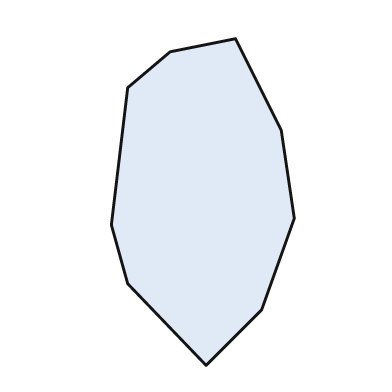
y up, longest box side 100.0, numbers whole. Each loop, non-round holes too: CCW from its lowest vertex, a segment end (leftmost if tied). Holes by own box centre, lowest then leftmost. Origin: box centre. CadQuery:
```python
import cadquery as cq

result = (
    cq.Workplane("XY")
    .moveTo(1.0, -50.0)
    .lineTo(18.0, -33.0)
    .lineTo(28.0, -5.0)
    .lineTo(24.0, 22.0)
    .lineTo(10.0, 50.0)
    .lineTo(-10.0, 46.0)
    .lineTo(-23.0, 35.0)
    .lineTo(-28.0, -7.0)
    .lineTo(-23.0, -25.0)
    .close()
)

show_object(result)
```